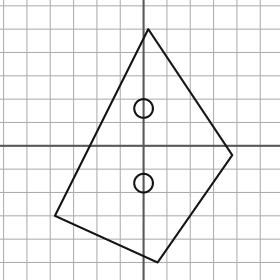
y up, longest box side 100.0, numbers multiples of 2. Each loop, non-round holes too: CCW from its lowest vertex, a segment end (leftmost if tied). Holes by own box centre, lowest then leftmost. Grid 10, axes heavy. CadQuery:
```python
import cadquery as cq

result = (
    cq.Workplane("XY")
    .moveTo(6.0, -50.0)
    .lineTo(38.0, -4.0)
    .lineTo(2.0, 50.0)
    .lineTo(-38.0, -30.0)
    .close()
    .moveTo(0.0, -16.0)
    .circle(4.0)
    .moveTo(0.0, 16.0)
    .circle(4.0)
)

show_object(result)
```